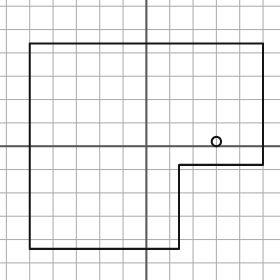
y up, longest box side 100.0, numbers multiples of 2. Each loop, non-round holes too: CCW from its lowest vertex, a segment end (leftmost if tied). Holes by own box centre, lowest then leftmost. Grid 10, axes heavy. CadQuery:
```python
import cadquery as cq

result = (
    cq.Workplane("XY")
    .moveTo(-50.0, -44.0)
    .lineTo(14.0, -44.0)
    .lineTo(14.0, -8.0)
    .lineTo(50.0, -8.0)
    .lineTo(50.0, 44.0)
    .lineTo(-50.0, 44.0)
    .close()
    .moveTo(30.0, 2.0)
    .circle(2.0)
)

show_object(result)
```